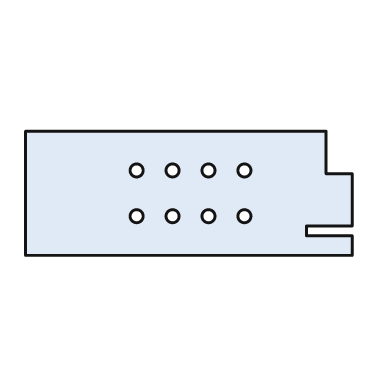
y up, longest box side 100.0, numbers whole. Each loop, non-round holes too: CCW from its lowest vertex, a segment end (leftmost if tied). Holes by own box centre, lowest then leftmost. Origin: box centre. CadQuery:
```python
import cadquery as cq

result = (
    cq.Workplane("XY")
    .moveTo(-50.0, -19.0)
    .lineTo(50.0, -19.0)
    .lineTo(50.0, -13.0)
    .lineTo(36.0, -13.0)
    .lineTo(36.0, -10.0)
    .lineTo(50.0, -10.0)
    .lineTo(50.0, 6.0)
    .lineTo(42.0, 6.0)
    .lineTo(42.0, 19.0)
    .lineTo(-50.0, 19.0)
    .close()
    .moveTo(-16.0, -7.0)
    .circle(2.0)
    .moveTo(-5.0, -7.0)
    .circle(2.0)
    .moveTo(6.0, -7.0)
    .circle(2.0)
    .moveTo(17.0, -7.0)
    .circle(2.0)
    .moveTo(-16.0, 7.0)
    .circle(2.0)
    .moveTo(-5.0, 7.0)
    .circle(2.0)
    .moveTo(6.0, 7.0)
    .circle(2.0)
    .moveTo(17.0, 7.0)
    .circle(2.0)
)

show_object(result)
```